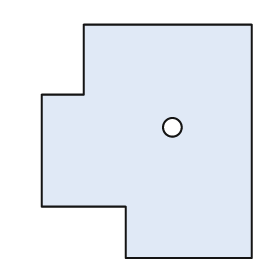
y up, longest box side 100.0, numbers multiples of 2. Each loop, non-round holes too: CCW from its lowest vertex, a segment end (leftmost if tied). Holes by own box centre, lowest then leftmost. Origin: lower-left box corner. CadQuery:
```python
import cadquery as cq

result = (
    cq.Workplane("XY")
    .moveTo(36.0, 0.0)
    .lineTo(90.0, 0.0)
    .lineTo(90.0, 100.0)
    .lineTo(18.0, 100.0)
    .lineTo(18.0, 70.0)
    .lineTo(0.0, 70.0)
    .lineTo(0.0, 22.0)
    .lineTo(36.0, 22.0)
    .close()
    .moveTo(56.0, 56.0)
    .circle(4.0)
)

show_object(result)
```